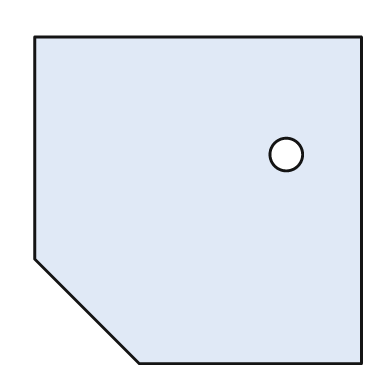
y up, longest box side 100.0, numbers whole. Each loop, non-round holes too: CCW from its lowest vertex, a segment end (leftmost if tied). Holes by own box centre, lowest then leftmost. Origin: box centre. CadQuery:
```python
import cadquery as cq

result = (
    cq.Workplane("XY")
    .moveTo(-18.0, -50.0)
    .lineTo(50.0, -50.0)
    .lineTo(50.0, 50.0)
    .lineTo(-50.0, 50.0)
    .lineTo(-50.0, -18.0)
    .close()
    .moveTo(27.0, 14.0)
    .circle(5.0)
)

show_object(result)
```